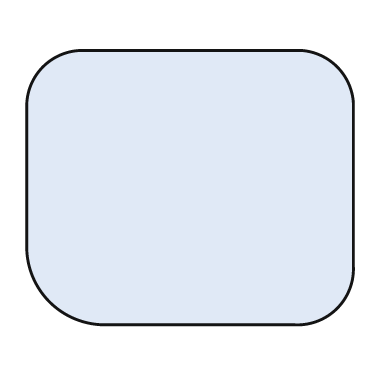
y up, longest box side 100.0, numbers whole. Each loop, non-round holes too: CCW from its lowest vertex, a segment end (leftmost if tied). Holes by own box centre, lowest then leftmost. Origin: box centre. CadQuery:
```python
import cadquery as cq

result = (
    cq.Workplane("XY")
    .moveTo(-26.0, -42.0)
    .lineTo(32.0, -42.0)
    .threePointArc((45.0, -37.0), (50.0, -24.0))
    .lineTo(50.0, 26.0)
    .threePointArc((45.0, 37.0), (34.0, 42.0))
    .lineTo(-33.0, 42.0)
    .threePointArc((-45.0, 37.0), (-50.0, 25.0))
    .lineTo(-50.0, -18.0)
    .threePointArc((-43.0, -35.0), (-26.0, -42.0))
    .close()
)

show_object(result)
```